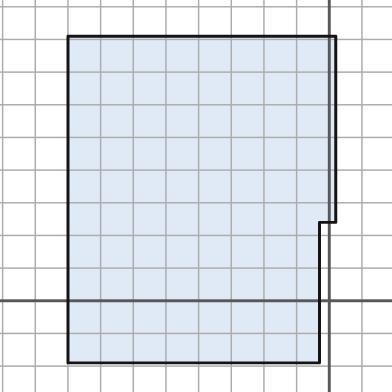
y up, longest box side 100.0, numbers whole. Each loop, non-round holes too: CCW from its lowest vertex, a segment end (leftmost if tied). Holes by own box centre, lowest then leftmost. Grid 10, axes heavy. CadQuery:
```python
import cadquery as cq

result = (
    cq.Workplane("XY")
    .moveTo(-80.0, -19.0)
    .lineTo(-3.0, -19.0)
    .lineTo(-3.0, 24.0)
    .lineTo(2.0, 24.0)
    .lineTo(2.0, 81.0)
    .lineTo(-80.0, 81.0)
    .close()
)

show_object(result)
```